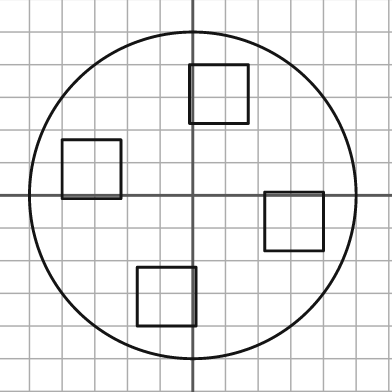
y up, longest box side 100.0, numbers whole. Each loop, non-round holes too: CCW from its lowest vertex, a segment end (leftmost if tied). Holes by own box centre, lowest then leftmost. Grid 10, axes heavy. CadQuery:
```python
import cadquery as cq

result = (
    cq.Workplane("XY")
    .moveTo(0.0, 0.0)
    .circle(50.0)
    .moveTo(-17.0, -40.0)
    .lineTo(1.0, -40.0)
    .lineTo(1.0, -22.0)
    .lineTo(-17.0, -22.0)
    .close()
    .moveTo(22.0, -17.0)
    .lineTo(40.0, -17.0)
    .lineTo(40.0, 1.0)
    .lineTo(22.0, 1.0)
    .close()
    .moveTo(-40.0, -1.0)
    .lineTo(-22.0, -1.0)
    .lineTo(-22.0, 17.0)
    .lineTo(-40.0, 17.0)
    .close()
    .moveTo(-1.0, 22.0)
    .lineTo(17.0, 22.0)
    .lineTo(17.0, 40.0)
    .lineTo(-1.0, 40.0)
    .close()
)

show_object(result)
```